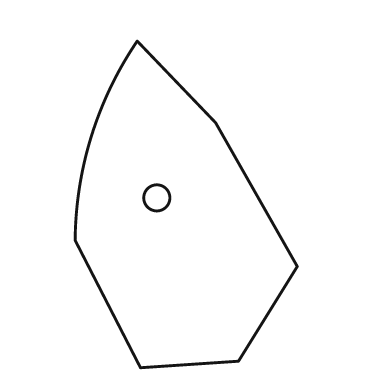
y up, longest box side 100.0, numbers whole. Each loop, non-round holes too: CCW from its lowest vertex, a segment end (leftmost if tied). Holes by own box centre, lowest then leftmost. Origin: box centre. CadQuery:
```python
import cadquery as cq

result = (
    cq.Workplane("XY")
    .moveTo(-14.0, -50.0)
    .lineTo(16.0, -48.0)
    .lineTo(34.0, -19.0)
    .lineTo(9.0, 25.0)
    .lineTo(-15.0, 50.0)
    .threePointArc((-29.0, 21.0), (-34.0, -11.0))
    .close()
    .moveTo(-9.0, 2.0)
    .circle(4.0)
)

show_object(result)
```